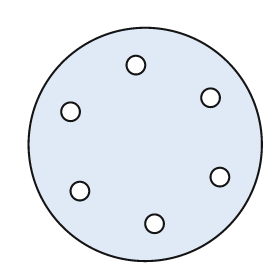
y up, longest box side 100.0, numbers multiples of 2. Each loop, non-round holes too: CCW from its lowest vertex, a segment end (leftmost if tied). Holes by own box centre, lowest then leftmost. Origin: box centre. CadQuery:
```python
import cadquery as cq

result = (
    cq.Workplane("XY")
    .moveTo(0.0, 0.0)
    .circle(50.0)
    .moveTo(4.0, -34.0)
    .circle(4.0)
    .moveTo(-28.0, -20.0)
    .circle(4.0)
    .moveTo(32.0, -14.0)
    .circle(4.0)
    .moveTo(-32.0, 14.0)
    .circle(4.0)
    .moveTo(28.0, 20.0)
    .circle(4.0)
    .moveTo(-4.0, 34.0)
    .circle(4.0)
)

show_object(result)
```